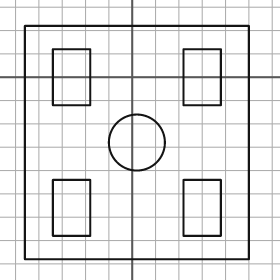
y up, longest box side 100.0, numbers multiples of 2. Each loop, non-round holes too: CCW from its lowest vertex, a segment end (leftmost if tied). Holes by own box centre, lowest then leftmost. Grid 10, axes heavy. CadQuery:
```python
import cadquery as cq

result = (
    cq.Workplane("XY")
    .moveTo(-46.0, -78.0)
    .lineTo(50.0, -78.0)
    .lineTo(50.0, 22.0)
    .lineTo(-46.0, 22.0)
    .close()
    .moveTo(-34.0, -68.0)
    .lineTo(-18.0, -68.0)
    .lineTo(-18.0, -44.0)
    .lineTo(-34.0, -44.0)
    .close()
    .moveTo(22.0, -68.0)
    .lineTo(38.0, -68.0)
    .lineTo(38.0, -44.0)
    .lineTo(22.0, -44.0)
    .close()
    .moveTo(2.0, -28.0)
    .circle(12.0)
    .moveTo(-34.0, -12.0)
    .lineTo(-18.0, -12.0)
    .lineTo(-18.0, 12.0)
    .lineTo(-34.0, 12.0)
    .close()
    .moveTo(22.0, -12.0)
    .lineTo(38.0, -12.0)
    .lineTo(38.0, 12.0)
    .lineTo(22.0, 12.0)
    .close()
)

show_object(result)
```